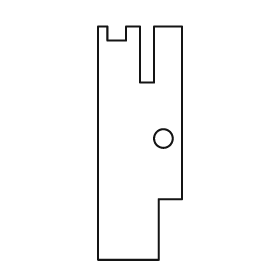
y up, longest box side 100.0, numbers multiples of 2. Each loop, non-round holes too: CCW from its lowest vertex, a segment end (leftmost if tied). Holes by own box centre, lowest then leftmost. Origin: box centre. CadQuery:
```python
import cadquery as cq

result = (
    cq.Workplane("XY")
    .moveTo(-18.0, -50.0)
    .lineTo(8.0, -50.0)
    .lineTo(8.0, -24.0)
    .lineTo(18.0, -24.0)
    .lineTo(18.0, 50.0)
    .lineTo(6.0, 50.0)
    .lineTo(6.0, 26.0)
    .lineTo(0.0, 26.0)
    .lineTo(0.0, 50.0)
    .lineTo(-6.0, 50.0)
    .lineTo(-6.0, 44.0)
    .lineTo(-14.0, 44.0)
    .lineTo(-14.0, 50.0)
    .lineTo(-18.0, 50.0)
    .close()
    .moveTo(10.0, 2.0)
    .circle(4.0)
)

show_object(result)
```